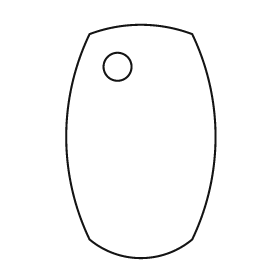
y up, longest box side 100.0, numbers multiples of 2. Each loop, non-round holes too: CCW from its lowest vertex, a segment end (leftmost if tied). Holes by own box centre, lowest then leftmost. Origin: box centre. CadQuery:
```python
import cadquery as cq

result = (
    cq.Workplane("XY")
    .moveTo(-22.0, -42.0)
    .threePointArc((0.0, -50.0), (22.0, -42.0))
    .threePointArc((32.0, 2.0), (22.0, 46.0))
    .threePointArc((0.0, 50.0), (-22.0, 46.0))
    .threePointArc((-32.0, 2.0), (-22.0, -42.0))
    .close()
    .moveTo(-10.0, 32.0)
    .circle(6.0)
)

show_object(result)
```